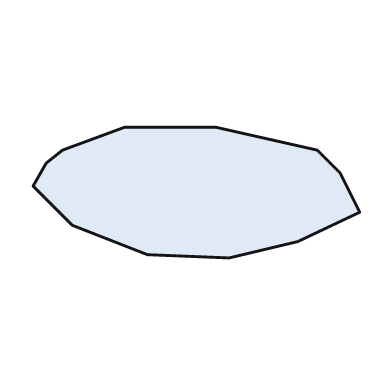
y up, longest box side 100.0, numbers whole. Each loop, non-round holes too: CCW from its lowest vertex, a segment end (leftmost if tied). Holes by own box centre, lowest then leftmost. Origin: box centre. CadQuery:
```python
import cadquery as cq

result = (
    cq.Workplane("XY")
    .moveTo(10.0, -20.0)
    .lineTo(31.0, -15.0)
    .lineTo(50.0, -6.0)
    .lineTo(44.0, 6.0)
    .lineTo(37.0, 13.0)
    .lineTo(6.0, 20.0)
    .lineTo(-22.0, 20.0)
    .lineTo(-41.0, 13.0)
    .lineTo(-46.0, 9.0)
    .lineTo(-50.0, 2.0)
    .lineTo(-38.0, -10.0)
    .lineTo(-15.0, -19.0)
    .close()
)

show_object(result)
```